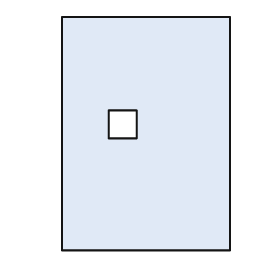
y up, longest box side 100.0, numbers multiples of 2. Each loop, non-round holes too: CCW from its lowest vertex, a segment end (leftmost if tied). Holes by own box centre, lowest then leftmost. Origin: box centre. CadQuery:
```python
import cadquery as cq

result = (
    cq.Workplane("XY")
    .moveTo(-36.0, -50.0)
    .lineTo(36.0, -50.0)
    .lineTo(36.0, 50.0)
    .lineTo(-36.0, 50.0)
    .close()
    .moveTo(-16.0, -2.0)
    .lineTo(-4.0, -2.0)
    .lineTo(-4.0, 10.0)
    .lineTo(-16.0, 10.0)
    .close()
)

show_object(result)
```